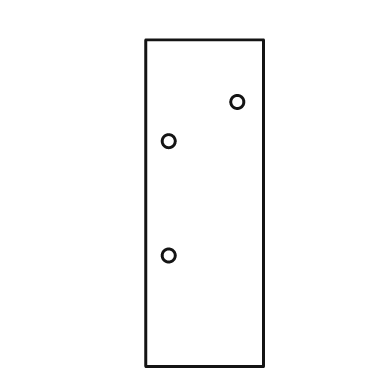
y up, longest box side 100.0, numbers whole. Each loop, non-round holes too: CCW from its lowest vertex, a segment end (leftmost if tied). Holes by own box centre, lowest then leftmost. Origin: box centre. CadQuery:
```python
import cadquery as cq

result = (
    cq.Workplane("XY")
    .moveTo(-18.0, -50.0)
    .lineTo(18.0, -50.0)
    .lineTo(18.0, 50.0)
    .lineTo(-18.0, 50.0)
    .close()
    .moveTo(-11.0, -16.0)
    .circle(2.0)
    .moveTo(-11.0, 19.0)
    .circle(2.0)
    .moveTo(10.0, 31.0)
    .circle(2.0)
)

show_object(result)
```